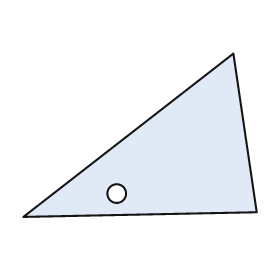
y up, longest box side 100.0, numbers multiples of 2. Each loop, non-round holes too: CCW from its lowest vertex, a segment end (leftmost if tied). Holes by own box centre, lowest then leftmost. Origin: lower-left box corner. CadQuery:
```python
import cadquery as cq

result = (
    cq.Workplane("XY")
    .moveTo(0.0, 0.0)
    .lineTo(100.0, 2.0)
    .lineTo(90.0, 70.0)
    .close()
    .moveTo(40.0, 10.0)
    .circle(4.0)
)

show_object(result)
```